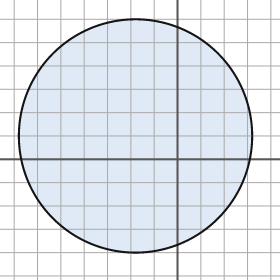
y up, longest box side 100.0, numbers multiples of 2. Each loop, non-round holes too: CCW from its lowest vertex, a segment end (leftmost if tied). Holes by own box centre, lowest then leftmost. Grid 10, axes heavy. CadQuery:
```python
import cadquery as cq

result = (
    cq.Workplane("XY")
    .moveTo(-18.0, 10.0)
    .circle(50.0)
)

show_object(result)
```